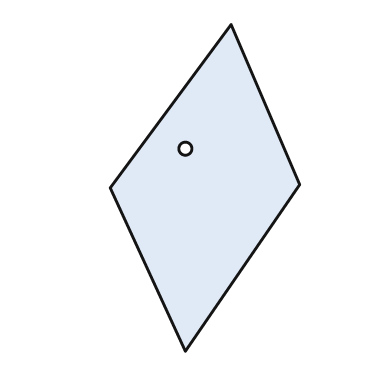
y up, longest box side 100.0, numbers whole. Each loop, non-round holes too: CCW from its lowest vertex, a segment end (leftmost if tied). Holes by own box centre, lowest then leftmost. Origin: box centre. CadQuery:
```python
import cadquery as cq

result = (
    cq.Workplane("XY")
    .moveTo(-6.0, -50.0)
    .lineTo(29.0, 1.0)
    .lineTo(8.0, 50.0)
    .lineTo(-29.0, 0.0)
    .close()
    .moveTo(-6.0, 12.0)
    .circle(2.0)
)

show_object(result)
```